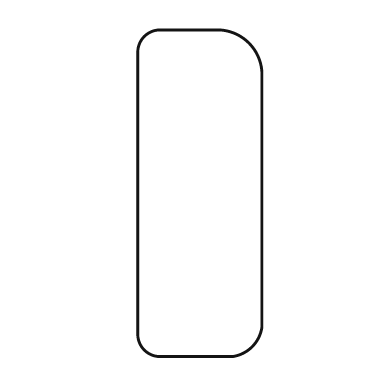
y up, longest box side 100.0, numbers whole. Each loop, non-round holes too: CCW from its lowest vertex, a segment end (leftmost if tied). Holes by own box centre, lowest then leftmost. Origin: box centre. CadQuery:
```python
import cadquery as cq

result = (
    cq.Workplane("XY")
    .moveTo(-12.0, -50.0)
    .lineTo(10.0, -50.0)
    .threePointArc((16.0, -47.0), (19.0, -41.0))
    .lineTo(19.0, 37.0)
    .threePointArc((15.0, 46.0), (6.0, 50.0))
    .lineTo(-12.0, 50.0)
    .threePointArc((-17.0, 48.0), (-19.0, 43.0))
    .lineTo(-19.0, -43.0)
    .threePointArc((-17.0, -48.0), (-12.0, -50.0))
    .close()
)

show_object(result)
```